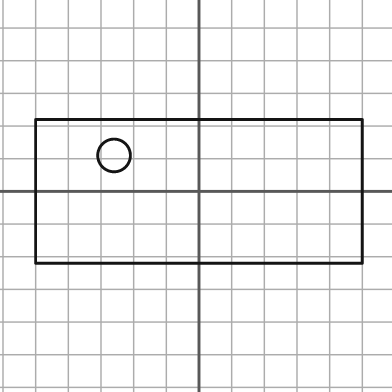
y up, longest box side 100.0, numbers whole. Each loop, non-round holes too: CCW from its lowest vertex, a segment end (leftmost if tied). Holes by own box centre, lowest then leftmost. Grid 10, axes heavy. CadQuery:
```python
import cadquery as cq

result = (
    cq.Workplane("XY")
    .moveTo(-50.0, -22.0)
    .lineTo(50.0, -22.0)
    .lineTo(50.0, 22.0)
    .lineTo(-50.0, 22.0)
    .close()
    .moveTo(-26.0, 11.0)
    .circle(5.0)
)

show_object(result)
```